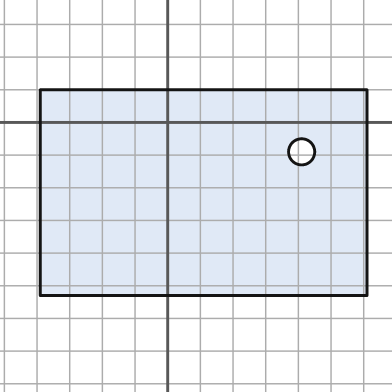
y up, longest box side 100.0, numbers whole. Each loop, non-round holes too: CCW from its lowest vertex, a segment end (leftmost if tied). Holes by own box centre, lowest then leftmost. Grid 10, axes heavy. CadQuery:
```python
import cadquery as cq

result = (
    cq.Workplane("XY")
    .moveTo(-39.0, -53.0)
    .lineTo(61.0, -53.0)
    .lineTo(61.0, 10.0)
    .lineTo(-39.0, 10.0)
    .close()
    .moveTo(41.0, -9.0)
    .circle(4.0)
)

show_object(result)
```